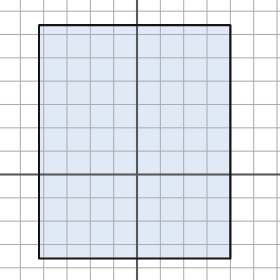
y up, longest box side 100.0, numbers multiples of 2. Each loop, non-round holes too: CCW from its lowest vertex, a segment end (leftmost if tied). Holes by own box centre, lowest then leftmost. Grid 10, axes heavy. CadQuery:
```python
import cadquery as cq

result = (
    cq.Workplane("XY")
    .moveTo(-42.0, -36.0)
    .lineTo(40.0, -36.0)
    .lineTo(40.0, 64.0)
    .lineTo(-42.0, 64.0)
    .close()
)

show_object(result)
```